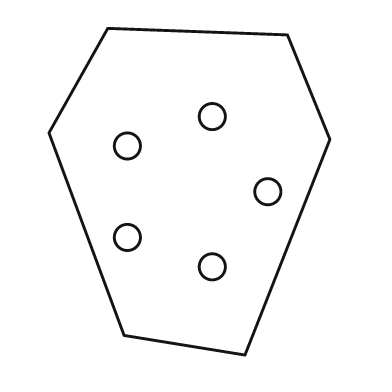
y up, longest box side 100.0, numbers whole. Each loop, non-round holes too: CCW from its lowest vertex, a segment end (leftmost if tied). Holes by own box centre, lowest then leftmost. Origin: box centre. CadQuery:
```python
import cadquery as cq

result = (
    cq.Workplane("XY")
    .moveTo(17.0, -50.0)
    .lineTo(43.0, 16.0)
    .lineTo(30.0, 48.0)
    .lineTo(-25.0, 50.0)
    .lineTo(-43.0, 18.0)
    .lineTo(-20.0, -44.0)
    .close()
    .moveTo(7.0, -23.0)
    .circle(4.0)
    .moveTo(-19.0, -14.0)
    .circle(4.0)
    .moveTo(24.0, 0.0)
    .circle(4.0)
    .moveTo(-19.0, 14.0)
    .circle(4.0)
    .moveTo(7.0, 23.0)
    .circle(4.0)
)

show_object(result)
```